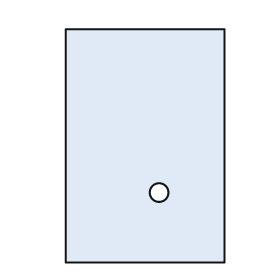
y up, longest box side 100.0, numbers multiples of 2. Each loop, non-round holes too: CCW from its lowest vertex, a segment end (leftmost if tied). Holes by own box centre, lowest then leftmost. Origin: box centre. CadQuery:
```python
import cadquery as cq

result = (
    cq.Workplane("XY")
    .moveTo(-34.0, -50.0)
    .lineTo(34.0, -50.0)
    .lineTo(34.0, 50.0)
    .lineTo(-34.0, 50.0)
    .close()
    .moveTo(6.0, -20.0)
    .circle(4.0)
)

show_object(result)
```